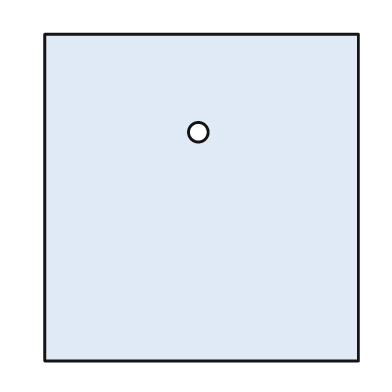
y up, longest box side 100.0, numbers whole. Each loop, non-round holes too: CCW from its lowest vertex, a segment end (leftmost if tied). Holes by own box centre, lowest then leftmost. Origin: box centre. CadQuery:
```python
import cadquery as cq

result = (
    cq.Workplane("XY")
    .moveTo(-48.0, -50.0)
    .lineTo(48.0, -50.0)
    .lineTo(48.0, 50.0)
    .lineTo(-48.0, 50.0)
    .close()
    .moveTo(-1.0, 20.0)
    .circle(3.0)
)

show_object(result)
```